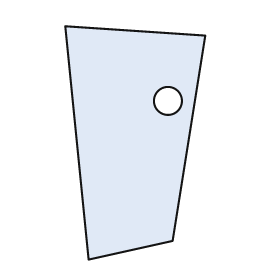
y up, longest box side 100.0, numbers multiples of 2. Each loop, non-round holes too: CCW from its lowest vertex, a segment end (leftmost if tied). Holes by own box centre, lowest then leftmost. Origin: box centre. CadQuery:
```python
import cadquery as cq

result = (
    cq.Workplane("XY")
    .moveTo(-20.0, -50.0)
    .lineTo(16.0, -42.0)
    .lineTo(30.0, 46.0)
    .lineTo(-30.0, 50.0)
    .close()
    .moveTo(14.0, 18.0)
    .circle(6.0)
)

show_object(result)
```